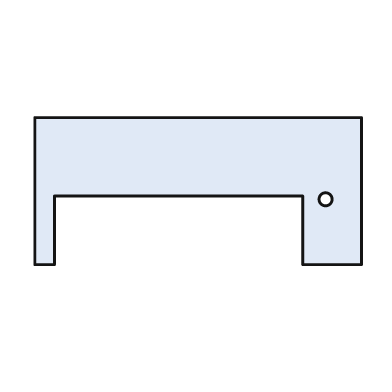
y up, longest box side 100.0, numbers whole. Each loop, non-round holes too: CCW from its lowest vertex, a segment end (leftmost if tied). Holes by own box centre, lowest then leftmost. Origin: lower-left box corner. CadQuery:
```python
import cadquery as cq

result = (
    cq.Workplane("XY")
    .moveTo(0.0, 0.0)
    .lineTo(6.0, 0.0)
    .lineTo(6.0, 21.0)
    .lineTo(82.0, 21.0)
    .lineTo(82.0, 0.0)
    .lineTo(100.0, 0.0)
    .lineTo(100.0, 45.0)
    .lineTo(0.0, 45.0)
    .close()
    .moveTo(89.0, 20.0)
    .circle(2.0)
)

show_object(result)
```